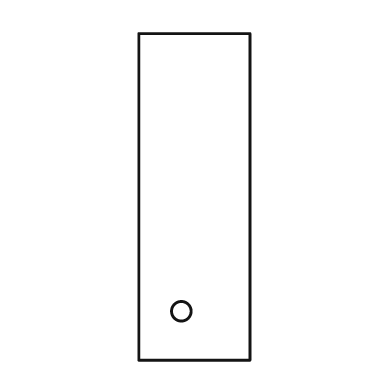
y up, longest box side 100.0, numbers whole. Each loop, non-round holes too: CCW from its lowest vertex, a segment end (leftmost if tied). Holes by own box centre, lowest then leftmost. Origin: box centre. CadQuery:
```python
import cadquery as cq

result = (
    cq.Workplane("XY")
    .moveTo(-17.0, -50.0)
    .lineTo(17.0, -50.0)
    .lineTo(17.0, 50.0)
    .lineTo(-17.0, 50.0)
    .close()
    .moveTo(-4.0, -35.0)
    .circle(3.0)
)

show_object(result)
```